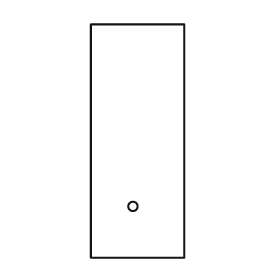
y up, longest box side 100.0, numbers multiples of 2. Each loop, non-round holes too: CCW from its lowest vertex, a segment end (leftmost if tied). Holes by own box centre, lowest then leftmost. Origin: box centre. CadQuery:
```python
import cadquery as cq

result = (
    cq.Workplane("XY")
    .moveTo(-20.0, -50.0)
    .lineTo(20.0, -50.0)
    .lineTo(20.0, 50.0)
    .lineTo(-20.0, 50.0)
    .close()
    .moveTo(-2.0, -28.0)
    .circle(2.0)
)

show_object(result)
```